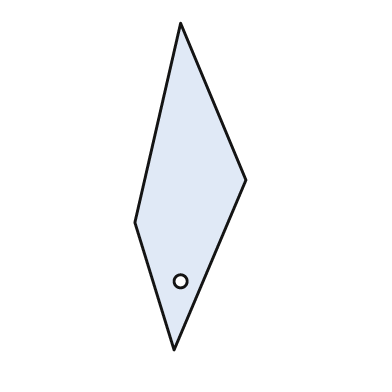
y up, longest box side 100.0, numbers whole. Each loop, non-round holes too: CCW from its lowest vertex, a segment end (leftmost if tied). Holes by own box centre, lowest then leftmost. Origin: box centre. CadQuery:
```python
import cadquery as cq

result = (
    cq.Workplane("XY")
    .moveTo(-5.0, -50.0)
    .lineTo(17.0, 2.0)
    .lineTo(-3.0, 50.0)
    .lineTo(-17.0, -11.0)
    .close()
    .moveTo(-3.0, -29.0)
    .circle(2.0)
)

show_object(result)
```